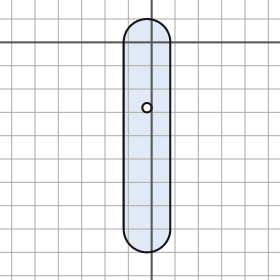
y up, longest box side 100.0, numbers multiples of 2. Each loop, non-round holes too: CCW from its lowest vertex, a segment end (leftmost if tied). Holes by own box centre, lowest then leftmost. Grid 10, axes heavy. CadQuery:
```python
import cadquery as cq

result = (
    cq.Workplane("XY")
    .moveTo(-12.0, -80.0)
    .threePointArc((-2.0, -90.0), (8.0, -80.0))
    .lineTo(8.0, 0.0)
    .threePointArc((-2.0, 10.0), (-12.0, 0.0))
    .close()
    .moveTo(-2.0, -28.0)
    .circle(2.0)
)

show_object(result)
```